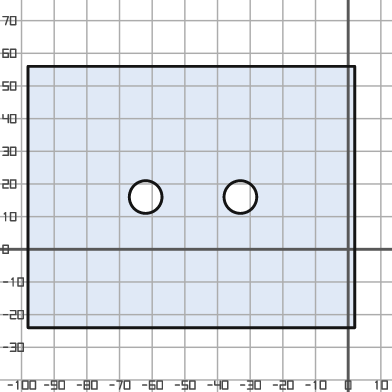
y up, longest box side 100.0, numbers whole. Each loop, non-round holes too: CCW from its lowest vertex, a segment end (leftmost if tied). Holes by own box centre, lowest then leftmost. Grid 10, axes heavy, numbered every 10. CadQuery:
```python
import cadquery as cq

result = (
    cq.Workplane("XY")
    .moveTo(-98.0, -24.0)
    .lineTo(2.0, -24.0)
    .lineTo(2.0, 56.0)
    .lineTo(-98.0, 56.0)
    .close()
    .moveTo(-62.0, 16.0)
    .circle(5.0)
    .moveTo(-33.0, 16.0)
    .circle(5.0)
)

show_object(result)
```